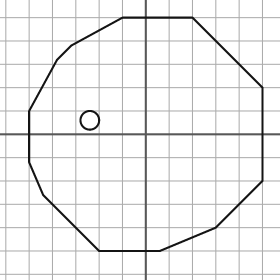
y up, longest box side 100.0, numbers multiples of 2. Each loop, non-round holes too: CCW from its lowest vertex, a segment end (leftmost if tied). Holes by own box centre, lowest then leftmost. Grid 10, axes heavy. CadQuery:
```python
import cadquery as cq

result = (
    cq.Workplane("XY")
    .moveTo(-20.0, -50.0)
    .lineTo(6.0, -50.0)
    .lineTo(30.0, -40.0)
    .lineTo(50.0, -20.0)
    .lineTo(50.0, 20.0)
    .lineTo(20.0, 50.0)
    .lineTo(-10.0, 50.0)
    .lineTo(-32.0, 38.0)
    .lineTo(-38.0, 32.0)
    .lineTo(-50.0, 10.0)
    .lineTo(-50.0, -12.0)
    .lineTo(-44.0, -26.0)
    .close()
    .moveTo(-24.0, 6.0)
    .circle(4.0)
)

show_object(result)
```